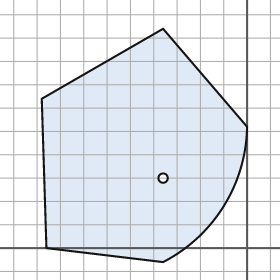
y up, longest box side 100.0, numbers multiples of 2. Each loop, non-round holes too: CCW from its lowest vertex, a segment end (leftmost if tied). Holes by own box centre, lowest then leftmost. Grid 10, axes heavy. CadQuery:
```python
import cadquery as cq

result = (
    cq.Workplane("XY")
    .moveTo(-36.0, -6.0)
    .threePointArc((-10.0, 18.0), (0.0, 52.0))
    .lineTo(-36.0, 94.0)
    .lineTo(-88.0, 64.0)
    .lineTo(-86.0, 0.0)
    .close()
    .moveTo(-36.0, 30.0)
    .circle(2.0)
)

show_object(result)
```